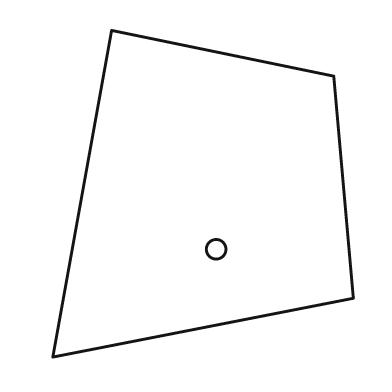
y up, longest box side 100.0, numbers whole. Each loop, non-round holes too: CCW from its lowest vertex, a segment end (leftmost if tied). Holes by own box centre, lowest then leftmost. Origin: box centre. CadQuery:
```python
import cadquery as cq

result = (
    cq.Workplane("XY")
    .moveTo(-46.0, -50.0)
    .lineTo(46.0, -32.0)
    .lineTo(40.0, 36.0)
    .lineTo(-28.0, 50.0)
    .close()
    .moveTo(4.0, -17.0)
    .circle(3.0)
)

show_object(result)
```